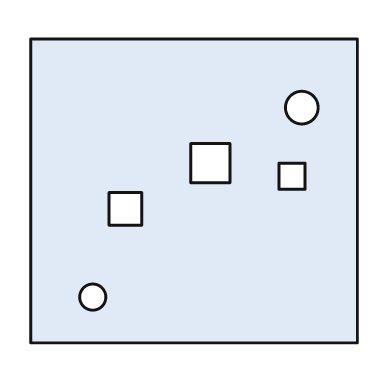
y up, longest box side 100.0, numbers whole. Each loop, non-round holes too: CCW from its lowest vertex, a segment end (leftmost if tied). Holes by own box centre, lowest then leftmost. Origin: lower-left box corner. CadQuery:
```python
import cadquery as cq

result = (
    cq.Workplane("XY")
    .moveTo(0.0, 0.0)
    .lineTo(100.0, 0.0)
    .lineTo(100.0, 93.0)
    .lineTo(0.0, 93.0)
    .close()
    .moveTo(19.0, 14.0)
    .circle(4.0)
    .moveTo(24.0, 36.0)
    .lineTo(34.0, 36.0)
    .lineTo(34.0, 46.0)
    .lineTo(24.0, 46.0)
    .close()
    .moveTo(76.0, 47.0)
    .lineTo(84.0, 47.0)
    .lineTo(84.0, 55.0)
    .lineTo(76.0, 55.0)
    .close()
    .moveTo(49.0, 49.0)
    .lineTo(61.0, 49.0)
    .lineTo(61.0, 61.0)
    .lineTo(49.0, 61.0)
    .close()
    .moveTo(83.0, 72.0)
    .circle(5.0)
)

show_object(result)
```